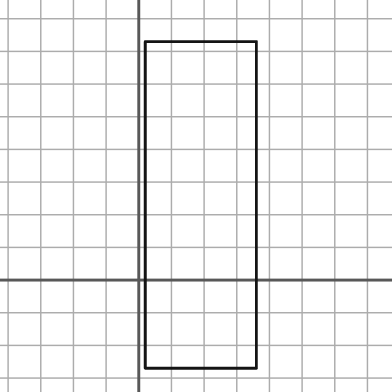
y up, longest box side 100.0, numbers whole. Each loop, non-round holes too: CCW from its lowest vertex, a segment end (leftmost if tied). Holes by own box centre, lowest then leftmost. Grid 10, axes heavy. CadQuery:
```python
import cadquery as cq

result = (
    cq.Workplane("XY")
    .moveTo(2.0, -27.0)
    .lineTo(36.0, -27.0)
    .lineTo(36.0, 73.0)
    .lineTo(2.0, 73.0)
    .close()
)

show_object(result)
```